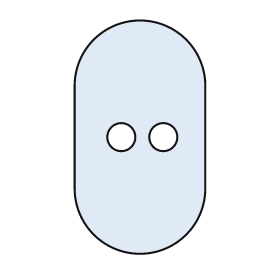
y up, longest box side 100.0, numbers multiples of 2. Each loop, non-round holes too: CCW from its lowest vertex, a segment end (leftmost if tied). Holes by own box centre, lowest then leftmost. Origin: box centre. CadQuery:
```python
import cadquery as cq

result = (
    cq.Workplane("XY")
    .moveTo(-28.0, -22.0)
    .threePointArc((0.0, -50.0), (28.0, -22.0))
    .lineTo(28.0, 22.0)
    .threePointArc((0.0, 50.0), (-28.0, 22.0))
    .close()
    .moveTo(-8.0, 0.0)
    .circle(6.0)
    .moveTo(10.0, 0.0)
    .circle(6.0)
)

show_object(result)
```